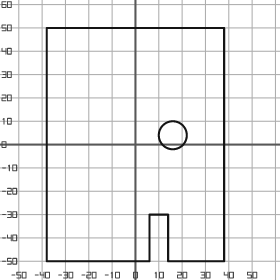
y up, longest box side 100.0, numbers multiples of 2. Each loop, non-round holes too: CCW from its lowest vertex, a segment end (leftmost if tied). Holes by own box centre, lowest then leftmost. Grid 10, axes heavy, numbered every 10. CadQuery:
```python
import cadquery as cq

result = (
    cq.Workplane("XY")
    .moveTo(-38.0, -50.0)
    .lineTo(6.0, -50.0)
    .lineTo(6.0, -30.0)
    .lineTo(14.0, -30.0)
    .lineTo(14.0, -50.0)
    .lineTo(38.0, -50.0)
    .lineTo(38.0, 50.0)
    .lineTo(-38.0, 50.0)
    .close()
    .moveTo(16.0, 4.0)
    .circle(6.0)
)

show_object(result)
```